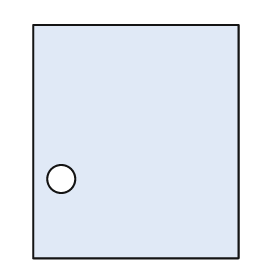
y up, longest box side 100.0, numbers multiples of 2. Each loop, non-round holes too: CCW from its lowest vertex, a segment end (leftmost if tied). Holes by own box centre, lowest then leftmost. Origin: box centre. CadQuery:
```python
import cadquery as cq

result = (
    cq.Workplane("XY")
    .moveTo(-44.0, -50.0)
    .lineTo(44.0, -50.0)
    .lineTo(44.0, 50.0)
    .lineTo(-44.0, 50.0)
    .close()
    .moveTo(-32.0, -16.0)
    .circle(6.0)
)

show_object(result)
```